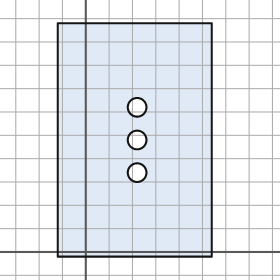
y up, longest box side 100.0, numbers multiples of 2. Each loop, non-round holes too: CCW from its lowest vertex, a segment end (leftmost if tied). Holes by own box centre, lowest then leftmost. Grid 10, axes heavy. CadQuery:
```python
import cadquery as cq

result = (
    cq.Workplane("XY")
    .moveTo(-12.0, -2.0)
    .lineTo(54.0, -2.0)
    .lineTo(54.0, 98.0)
    .lineTo(-12.0, 98.0)
    .close()
    .moveTo(22.0, 34.0)
    .circle(4.0)
    .moveTo(22.0, 48.0)
    .circle(4.0)
    .moveTo(22.0, 62.0)
    .circle(4.0)
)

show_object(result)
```